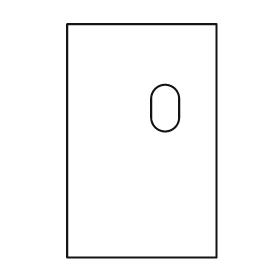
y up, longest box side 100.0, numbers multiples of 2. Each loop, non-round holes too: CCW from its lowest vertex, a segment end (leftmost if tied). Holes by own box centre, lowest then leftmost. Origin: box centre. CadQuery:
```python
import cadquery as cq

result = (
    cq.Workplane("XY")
    .moveTo(-32.0, -50.0)
    .lineTo(32.0, -50.0)
    .lineTo(32.0, 50.0)
    .lineTo(-32.0, 50.0)
    .close()
    .moveTo(4.0, 10.0)
    .threePointArc((10.0, 4.0), (16.0, 10.0))
    .lineTo(16.0, 18.0)
    .threePointArc((10.0, 24.0), (4.0, 18.0))
    .close()
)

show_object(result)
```